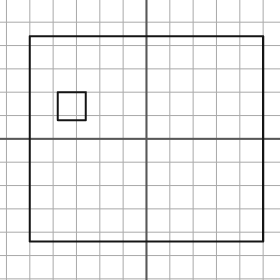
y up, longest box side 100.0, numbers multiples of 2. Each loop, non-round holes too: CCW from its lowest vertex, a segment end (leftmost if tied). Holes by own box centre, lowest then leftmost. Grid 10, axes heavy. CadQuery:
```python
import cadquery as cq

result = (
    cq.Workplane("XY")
    .moveTo(-50.0, -44.0)
    .lineTo(50.0, -44.0)
    .lineTo(50.0, 44.0)
    .lineTo(-50.0, 44.0)
    .close()
    .moveTo(-38.0, 8.0)
    .lineTo(-26.0, 8.0)
    .lineTo(-26.0, 20.0)
    .lineTo(-38.0, 20.0)
    .close()
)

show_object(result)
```